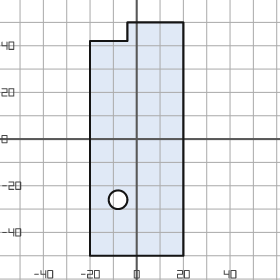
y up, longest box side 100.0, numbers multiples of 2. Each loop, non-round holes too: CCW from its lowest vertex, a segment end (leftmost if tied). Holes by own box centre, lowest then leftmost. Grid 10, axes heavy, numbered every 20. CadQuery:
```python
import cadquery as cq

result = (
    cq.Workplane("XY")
    .moveTo(-20.0, -50.0)
    .lineTo(20.0, -50.0)
    .lineTo(20.0, 50.0)
    .lineTo(-4.0, 50.0)
    .lineTo(-4.0, 42.0)
    .lineTo(-20.0, 42.0)
    .close()
    .moveTo(-8.0, -26.0)
    .circle(4.0)
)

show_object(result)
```